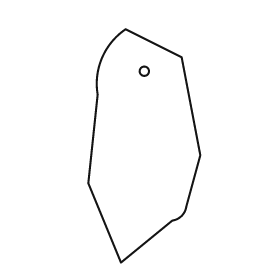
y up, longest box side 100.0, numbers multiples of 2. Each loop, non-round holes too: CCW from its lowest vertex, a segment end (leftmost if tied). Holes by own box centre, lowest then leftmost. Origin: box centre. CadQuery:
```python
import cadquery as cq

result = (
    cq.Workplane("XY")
    .moveTo(-10.0, -50.0)
    .lineTo(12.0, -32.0)
    .threePointArc((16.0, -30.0), (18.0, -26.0))
    .lineTo(24.0, -4.0)
    .lineTo(16.0, 38.0)
    .lineTo(-8.0, 50.0)
    .threePointArc((-18.0, 38.0), (-20.0, 22.0))
    .lineTo(-24.0, -16.0)
    .close()
    .moveTo(0.0, 32.0)
    .circle(2.0)
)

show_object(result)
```